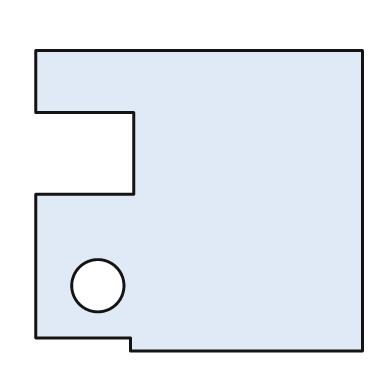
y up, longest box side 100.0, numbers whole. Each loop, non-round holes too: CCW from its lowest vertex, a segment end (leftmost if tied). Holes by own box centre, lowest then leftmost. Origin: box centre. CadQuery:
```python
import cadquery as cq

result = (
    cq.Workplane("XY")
    .moveTo(-21.0, -46.0)
    .lineTo(50.0, -46.0)
    .lineTo(50.0, 46.0)
    .lineTo(-50.0, 46.0)
    .lineTo(-50.0, 27.0)
    .lineTo(-20.0, 27.0)
    .lineTo(-20.0, 2.0)
    .lineTo(-50.0, 2.0)
    .lineTo(-50.0, -42.0)
    .lineTo(-21.0, -42.0)
    .close()
    .moveTo(-31.0, -26.0)
    .circle(8.0)
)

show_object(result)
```